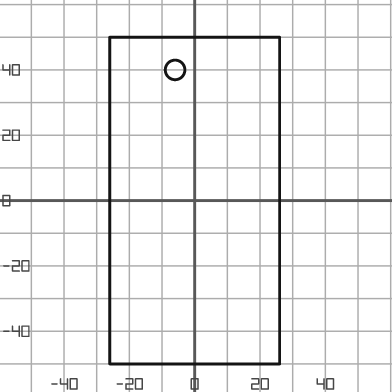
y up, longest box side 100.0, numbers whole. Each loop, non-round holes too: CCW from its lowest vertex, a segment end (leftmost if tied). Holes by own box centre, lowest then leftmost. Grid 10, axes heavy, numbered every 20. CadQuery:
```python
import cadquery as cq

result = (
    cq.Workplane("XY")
    .moveTo(-26.0, -50.0)
    .lineTo(26.0, -50.0)
    .lineTo(26.0, 50.0)
    .lineTo(-26.0, 50.0)
    .close()
    .moveTo(-6.0, 40.0)
    .circle(3.0)
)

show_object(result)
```